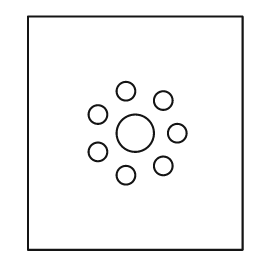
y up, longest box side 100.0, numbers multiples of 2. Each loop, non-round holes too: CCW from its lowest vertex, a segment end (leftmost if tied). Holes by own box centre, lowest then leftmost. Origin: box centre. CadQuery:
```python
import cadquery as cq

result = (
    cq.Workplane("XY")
    .moveTo(-46.0, -50.0)
    .lineTo(46.0, -50.0)
    .lineTo(46.0, 50.0)
    .lineTo(-46.0, 50.0)
    .close()
    .moveTo(-4.0, -18.0)
    .circle(4.0)
    .moveTo(12.0, -14.0)
    .circle(4.0)
    .moveTo(-16.0, -8.0)
    .circle(4.0)
    .moveTo(0.0, 0.0)
    .circle(8.0)
    .moveTo(18.0, 0.0)
    .circle(4.0)
    .moveTo(-16.0, 8.0)
    .circle(4.0)
    .moveTo(12.0, 14.0)
    .circle(4.0)
    .moveTo(-4.0, 18.0)
    .circle(4.0)
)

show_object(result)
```